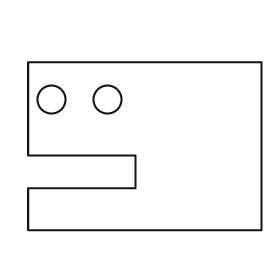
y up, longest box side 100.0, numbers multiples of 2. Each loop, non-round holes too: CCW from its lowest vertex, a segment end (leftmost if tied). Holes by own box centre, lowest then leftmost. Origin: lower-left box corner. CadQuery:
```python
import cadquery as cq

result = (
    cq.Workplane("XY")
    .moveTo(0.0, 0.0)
    .lineTo(100.0, 0.0)
    .lineTo(100.0, 72.0)
    .lineTo(0.0, 72.0)
    .lineTo(0.0, 32.0)
    .lineTo(46.0, 32.0)
    .lineTo(46.0, 18.0)
    .lineTo(0.0, 18.0)
    .close()
    .moveTo(10.0, 56.0)
    .circle(6.0)
    .moveTo(34.0, 56.0)
    .circle(6.0)
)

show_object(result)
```